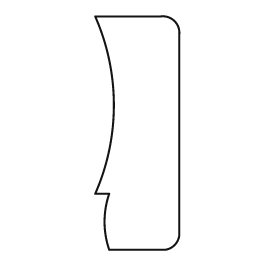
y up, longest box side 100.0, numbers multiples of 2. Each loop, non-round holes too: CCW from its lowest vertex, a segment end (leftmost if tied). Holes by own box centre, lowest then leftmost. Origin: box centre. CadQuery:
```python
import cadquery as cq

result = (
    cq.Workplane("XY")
    .moveTo(-12.0, -50.0)
    .lineTo(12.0, -50.0)
    .threePointArc((16.0, -48.0), (18.0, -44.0))
    .lineTo(18.0, 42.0)
    .threePointArc((16.0, 48.0), (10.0, 50.0))
    .lineTo(-18.0, 50.0)
    .threePointArc((-10.0, 12.0), (-18.0, -26.0))
    .lineTo(-12.0, -26.0)
    .threePointArc((-14.0, -38.0), (-12.0, -50.0))
    .close()
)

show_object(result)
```